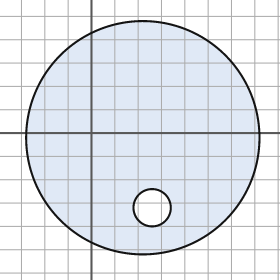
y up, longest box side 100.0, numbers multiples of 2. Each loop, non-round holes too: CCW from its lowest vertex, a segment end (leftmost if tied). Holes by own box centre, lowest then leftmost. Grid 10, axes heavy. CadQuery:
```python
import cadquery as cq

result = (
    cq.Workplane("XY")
    .moveTo(22.0, -2.0)
    .circle(50.0)
    .moveTo(26.0, -32.0)
    .circle(8.0)
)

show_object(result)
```